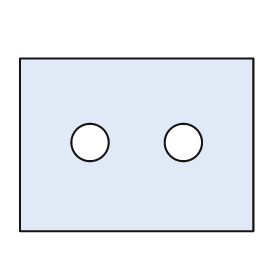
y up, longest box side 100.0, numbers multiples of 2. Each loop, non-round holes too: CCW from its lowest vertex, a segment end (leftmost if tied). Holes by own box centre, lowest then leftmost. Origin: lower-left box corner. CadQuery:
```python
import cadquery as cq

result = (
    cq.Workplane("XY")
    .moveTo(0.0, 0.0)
    .lineTo(100.0, 0.0)
    .lineTo(100.0, 74.0)
    .lineTo(0.0, 74.0)
    .close()
    .moveTo(30.0, 38.0)
    .circle(8.0)
    .moveTo(70.0, 38.0)
    .circle(8.0)
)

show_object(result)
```